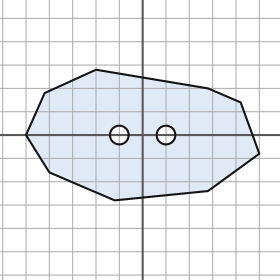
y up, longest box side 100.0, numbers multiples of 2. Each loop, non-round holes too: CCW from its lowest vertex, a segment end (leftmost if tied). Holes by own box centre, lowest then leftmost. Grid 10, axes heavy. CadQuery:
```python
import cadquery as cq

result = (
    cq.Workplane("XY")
    .moveTo(-12.0, -28.0)
    .lineTo(28.0, -24.0)
    .lineTo(50.0, -8.0)
    .lineTo(42.0, 14.0)
    .lineTo(28.0, 20.0)
    .lineTo(-20.0, 28.0)
    .lineTo(-42.0, 18.0)
    .lineTo(-50.0, 0.0)
    .lineTo(-40.0, -16.0)
    .close()
    .moveTo(-10.0, 0.0)
    .circle(4.0)
    .moveTo(10.0, 0.0)
    .circle(4.0)
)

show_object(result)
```